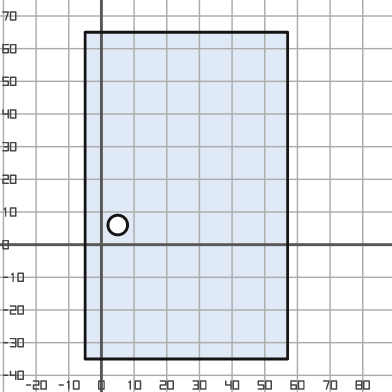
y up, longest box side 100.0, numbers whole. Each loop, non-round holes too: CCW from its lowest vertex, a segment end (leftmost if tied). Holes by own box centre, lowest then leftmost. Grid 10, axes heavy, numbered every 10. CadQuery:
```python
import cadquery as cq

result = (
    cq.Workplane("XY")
    .moveTo(-5.0, -35.0)
    .lineTo(57.0, -35.0)
    .lineTo(57.0, 65.0)
    .lineTo(-5.0, 65.0)
    .close()
    .moveTo(5.0, 6.0)
    .circle(3.0)
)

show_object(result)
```